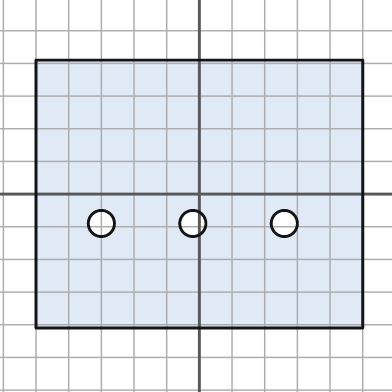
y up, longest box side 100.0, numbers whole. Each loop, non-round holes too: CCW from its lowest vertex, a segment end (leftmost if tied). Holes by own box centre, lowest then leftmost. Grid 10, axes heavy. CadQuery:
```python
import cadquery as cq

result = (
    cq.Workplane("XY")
    .moveTo(-50.0, -41.0)
    .lineTo(50.0, -41.0)
    .lineTo(50.0, 41.0)
    .lineTo(-50.0, 41.0)
    .close()
    .moveTo(-30.0, -9.0)
    .circle(4.0)
    .moveTo(-2.0, -9.0)
    .circle(4.0)
    .moveTo(26.0, -9.0)
    .circle(4.0)
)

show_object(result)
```